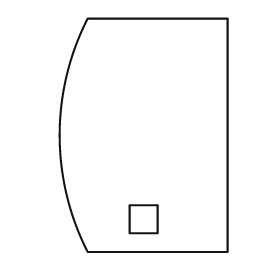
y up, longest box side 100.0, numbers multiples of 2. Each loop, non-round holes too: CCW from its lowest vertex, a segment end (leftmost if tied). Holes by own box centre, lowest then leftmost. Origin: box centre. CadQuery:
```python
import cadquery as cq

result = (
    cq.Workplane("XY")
    .moveTo(-24.0, -50.0)
    .lineTo(36.0, -50.0)
    .lineTo(36.0, 50.0)
    .lineTo(-24.0, 50.0)
    .threePointArc((-36.0, 0.0), (-24.0, -50.0))
    .close()
    .moveTo(-6.0, -42.0)
    .lineTo(6.0, -42.0)
    .lineTo(6.0, -30.0)
    .lineTo(-6.0, -30.0)
    .close()
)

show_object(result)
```